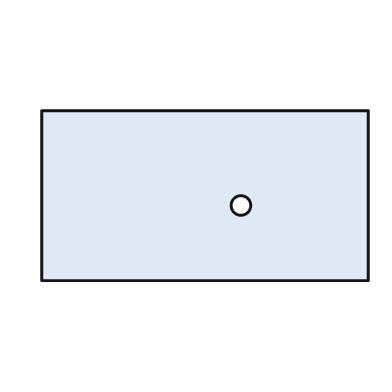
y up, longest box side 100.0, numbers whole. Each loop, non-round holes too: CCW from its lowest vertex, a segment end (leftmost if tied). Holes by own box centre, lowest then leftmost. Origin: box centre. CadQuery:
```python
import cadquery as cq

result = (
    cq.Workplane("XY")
    .moveTo(-50.0, -26.0)
    .lineTo(50.0, -26.0)
    .lineTo(50.0, 26.0)
    .lineTo(-50.0, 26.0)
    .close()
    .moveTo(11.0, -3.0)
    .circle(3.0)
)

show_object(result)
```